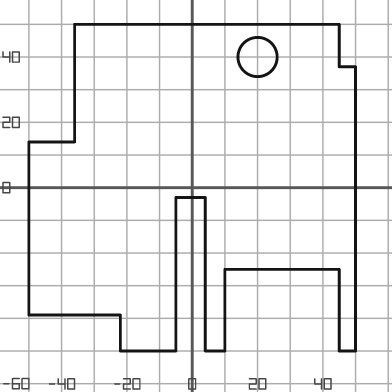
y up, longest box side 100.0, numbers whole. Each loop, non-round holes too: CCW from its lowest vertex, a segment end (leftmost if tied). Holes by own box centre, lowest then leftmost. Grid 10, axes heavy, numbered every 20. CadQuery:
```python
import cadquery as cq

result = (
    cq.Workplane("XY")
    .moveTo(-22.0, -50.0)
    .lineTo(-5.0, -50.0)
    .lineTo(-5.0, -3.0)
    .lineTo(4.0, -3.0)
    .lineTo(4.0, -50.0)
    .lineTo(10.0, -50.0)
    .lineTo(10.0, -25.0)
    .lineTo(45.0, -25.0)
    .lineTo(45.0, -50.0)
    .lineTo(50.0, -50.0)
    .lineTo(50.0, 37.0)
    .lineTo(45.0, 37.0)
    .lineTo(45.0, 50.0)
    .lineTo(-36.0, 50.0)
    .lineTo(-36.0, 14.0)
    .lineTo(-50.0, 14.0)
    .lineTo(-50.0, -39.0)
    .lineTo(-22.0, -39.0)
    .close()
    .moveTo(20.0, 40.0)
    .circle(6.0)
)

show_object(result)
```